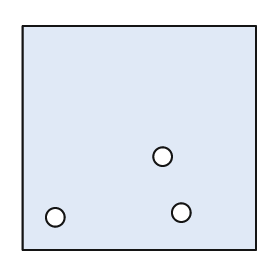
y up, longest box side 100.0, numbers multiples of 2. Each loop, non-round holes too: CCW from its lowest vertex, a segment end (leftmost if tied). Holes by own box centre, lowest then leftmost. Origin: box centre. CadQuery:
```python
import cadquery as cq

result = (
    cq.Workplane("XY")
    .moveTo(-50.0, -48.0)
    .lineTo(50.0, -48.0)
    .lineTo(50.0, 48.0)
    .lineTo(-50.0, 48.0)
    .close()
    .moveTo(-36.0, -34.0)
    .circle(4.0)
    .moveTo(18.0, -32.0)
    .circle(4.0)
    .moveTo(10.0, -8.0)
    .circle(4.0)
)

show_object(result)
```